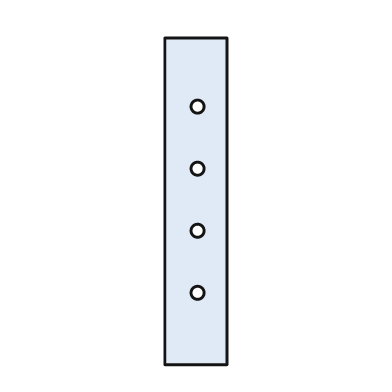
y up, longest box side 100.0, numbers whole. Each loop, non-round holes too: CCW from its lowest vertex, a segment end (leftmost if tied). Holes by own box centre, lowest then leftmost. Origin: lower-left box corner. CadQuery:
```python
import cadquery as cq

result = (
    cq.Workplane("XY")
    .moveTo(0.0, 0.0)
    .lineTo(19.0, 0.0)
    .lineTo(19.0, 100.0)
    .lineTo(0.0, 100.0)
    .close()
    .moveTo(10.0, 22.0)
    .circle(2.0)
    .moveTo(10.0, 41.0)
    .circle(2.0)
    .moveTo(10.0, 60.0)
    .circle(2.0)
    .moveTo(10.0, 79.0)
    .circle(2.0)
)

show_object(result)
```